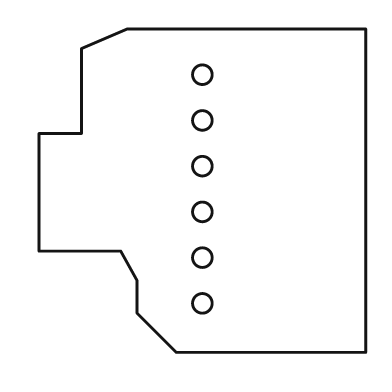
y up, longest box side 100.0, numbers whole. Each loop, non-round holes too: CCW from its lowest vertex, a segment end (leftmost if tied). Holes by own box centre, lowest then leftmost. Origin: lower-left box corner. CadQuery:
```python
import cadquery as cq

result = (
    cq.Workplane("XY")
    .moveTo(42.0, 0.0)
    .lineTo(100.0, 0.0)
    .lineTo(100.0, 99.0)
    .lineTo(27.0, 99.0)
    .lineTo(13.0, 93.0)
    .lineTo(13.0, 67.0)
    .lineTo(0.0, 67.0)
    .lineTo(0.0, 31.0)
    .lineTo(25.0, 31.0)
    .lineTo(30.0, 22.0)
    .lineTo(30.0, 12.0)
    .close()
    .moveTo(50.0, 15.0)
    .circle(3.0)
    .moveTo(50.0, 29.0)
    .circle(3.0)
    .moveTo(50.0, 43.0)
    .circle(3.0)
    .moveTo(50.0, 57.0)
    .circle(3.0)
    .moveTo(50.0, 71.0)
    .circle(3.0)
    .moveTo(50.0, 85.0)
    .circle(3.0)
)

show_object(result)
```